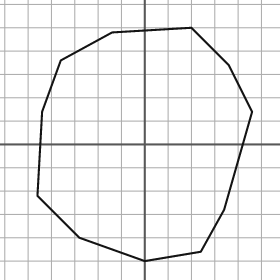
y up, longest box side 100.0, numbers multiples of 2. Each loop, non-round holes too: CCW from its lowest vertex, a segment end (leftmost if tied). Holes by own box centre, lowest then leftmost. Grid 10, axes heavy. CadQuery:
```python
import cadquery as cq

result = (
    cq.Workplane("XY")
    .moveTo(0.0, -50.0)
    .lineTo(24.0, -46.0)
    .lineTo(34.0, -28.0)
    .lineTo(46.0, 14.0)
    .lineTo(36.0, 34.0)
    .lineTo(20.0, 50.0)
    .lineTo(-14.0, 48.0)
    .lineTo(-36.0, 36.0)
    .lineTo(-44.0, 14.0)
    .lineTo(-46.0, -22.0)
    .lineTo(-28.0, -40.0)
    .close()
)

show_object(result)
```